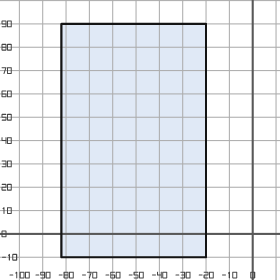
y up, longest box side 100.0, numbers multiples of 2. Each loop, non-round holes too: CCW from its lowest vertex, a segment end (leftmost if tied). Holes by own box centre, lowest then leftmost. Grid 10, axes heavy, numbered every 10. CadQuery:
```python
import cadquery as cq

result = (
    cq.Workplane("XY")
    .moveTo(-82.0, -10.0)
    .lineTo(-20.0, -10.0)
    .lineTo(-20.0, 90.0)
    .lineTo(-82.0, 90.0)
    .close()
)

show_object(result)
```